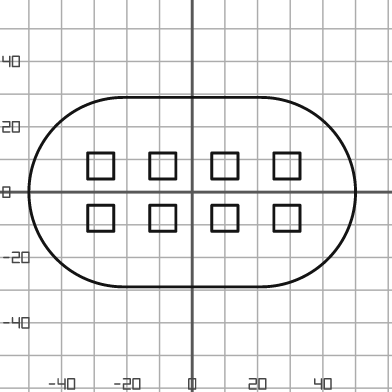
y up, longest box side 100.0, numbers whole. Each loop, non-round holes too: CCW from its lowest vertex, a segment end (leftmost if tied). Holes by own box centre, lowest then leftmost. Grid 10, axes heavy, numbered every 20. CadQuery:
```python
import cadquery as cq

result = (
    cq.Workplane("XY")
    .moveTo(-21.0, -29.0)
    .lineTo(21.0, -29.0)
    .threePointArc((50.0, 0.0), (21.0, 29.0))
    .lineTo(-21.0, 29.0)
    .threePointArc((-50.0, 0.0), (-21.0, -29.0))
    .close()
    .moveTo(-32.0, -12.0)
    .lineTo(-24.0, -12.0)
    .lineTo(-24.0, -4.0)
    .lineTo(-32.0, -4.0)
    .close()
    .moveTo(-13.0, -12.0)
    .lineTo(-5.0, -12.0)
    .lineTo(-5.0, -4.0)
    .lineTo(-13.0, -4.0)
    .close()
    .moveTo(6.0, -12.0)
    .lineTo(14.0, -12.0)
    .lineTo(14.0, -4.0)
    .lineTo(6.0, -4.0)
    .close()
    .moveTo(25.0, -12.0)
    .lineTo(33.0, -12.0)
    .lineTo(33.0, -4.0)
    .lineTo(25.0, -4.0)
    .close()
    .moveTo(-32.0, 4.0)
    .lineTo(-24.0, 4.0)
    .lineTo(-24.0, 12.0)
    .lineTo(-32.0, 12.0)
    .close()
    .moveTo(-13.0, 4.0)
    .lineTo(-5.0, 4.0)
    .lineTo(-5.0, 12.0)
    .lineTo(-13.0, 12.0)
    .close()
    .moveTo(6.0, 4.0)
    .lineTo(14.0, 4.0)
    .lineTo(14.0, 12.0)
    .lineTo(6.0, 12.0)
    .close()
    .moveTo(25.0, 4.0)
    .lineTo(33.0, 4.0)
    .lineTo(33.0, 12.0)
    .lineTo(25.0, 12.0)
    .close()
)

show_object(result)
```